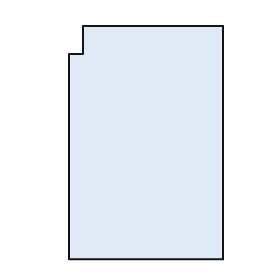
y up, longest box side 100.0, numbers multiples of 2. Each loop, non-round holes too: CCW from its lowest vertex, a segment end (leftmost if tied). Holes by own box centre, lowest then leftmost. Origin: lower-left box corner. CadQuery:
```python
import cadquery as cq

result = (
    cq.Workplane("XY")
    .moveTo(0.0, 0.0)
    .lineTo(66.0, 0.0)
    .lineTo(66.0, 100.0)
    .lineTo(6.0, 100.0)
    .lineTo(6.0, 88.0)
    .lineTo(0.0, 88.0)
    .close()
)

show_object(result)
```